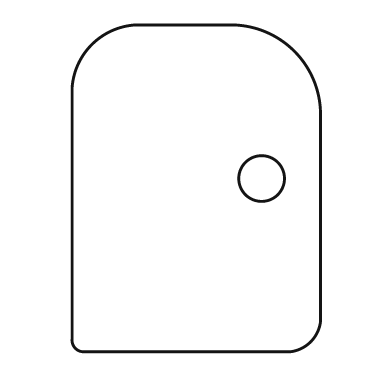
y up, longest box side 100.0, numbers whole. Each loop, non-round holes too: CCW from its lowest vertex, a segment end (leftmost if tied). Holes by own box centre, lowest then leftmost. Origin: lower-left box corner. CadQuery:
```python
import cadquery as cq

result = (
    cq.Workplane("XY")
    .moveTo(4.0, 0.0)
    .lineTo(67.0, 0.0)
    .threePointArc((73.0, 3.0), (76.0, 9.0))
    .lineTo(76.0, 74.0)
    .threePointArc((68.0, 92.0), (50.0, 100.0))
    .lineTo(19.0, 100.0)
    .threePointArc((6.0, 94.0), (0.0, 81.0))
    .lineTo(0.0, 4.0)
    .threePointArc((1.0, 1.0), (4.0, 0.0))
    .close()
    .moveTo(58.0, 53.0)
    .circle(7.0)
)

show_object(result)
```